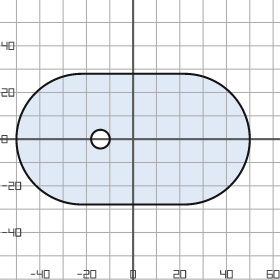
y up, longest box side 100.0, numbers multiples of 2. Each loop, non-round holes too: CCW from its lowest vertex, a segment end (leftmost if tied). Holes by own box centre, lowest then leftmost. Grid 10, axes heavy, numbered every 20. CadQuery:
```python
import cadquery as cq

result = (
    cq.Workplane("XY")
    .moveTo(-22.0, -28.0)
    .lineTo(22.0, -28.0)
    .threePointArc((50.0, 0.0), (22.0, 28.0))
    .lineTo(-22.0, 28.0)
    .threePointArc((-50.0, 0.0), (-22.0, -28.0))
    .close()
    .moveTo(-14.0, 0.0)
    .circle(4.0)
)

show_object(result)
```